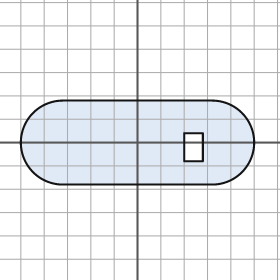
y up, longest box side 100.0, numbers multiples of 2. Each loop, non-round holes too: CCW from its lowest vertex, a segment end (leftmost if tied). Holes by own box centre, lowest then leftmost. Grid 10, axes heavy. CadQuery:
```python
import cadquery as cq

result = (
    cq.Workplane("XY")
    .moveTo(-32.0, -18.0)
    .lineTo(32.0, -18.0)
    .threePointArc((50.0, 0.0), (32.0, 18.0))
    .lineTo(-32.0, 18.0)
    .threePointArc((-50.0, 0.0), (-32.0, -18.0))
    .close()
    .moveTo(20.0, -8.0)
    .lineTo(28.0, -8.0)
    .lineTo(28.0, 4.0)
    .lineTo(20.0, 4.0)
    .close()
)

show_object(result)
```